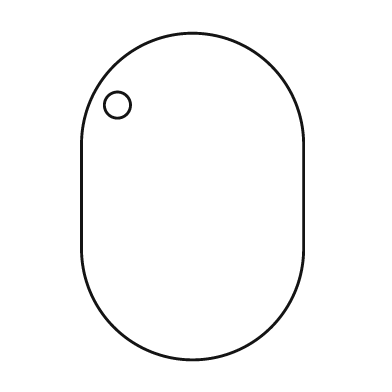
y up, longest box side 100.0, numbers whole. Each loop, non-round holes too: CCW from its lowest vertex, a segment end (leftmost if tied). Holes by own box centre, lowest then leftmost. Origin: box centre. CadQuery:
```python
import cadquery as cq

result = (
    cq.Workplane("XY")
    .moveTo(-34.0, -16.0)
    .threePointArc((0.0, -50.0), (34.0, -16.0))
    .lineTo(34.0, 16.0)
    .threePointArc((0.0, 50.0), (-34.0, 16.0))
    .close()
    .moveTo(-23.0, 28.0)
    .circle(4.0)
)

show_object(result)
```